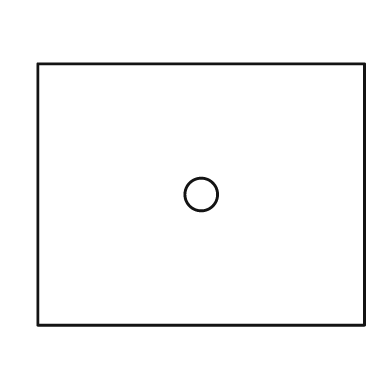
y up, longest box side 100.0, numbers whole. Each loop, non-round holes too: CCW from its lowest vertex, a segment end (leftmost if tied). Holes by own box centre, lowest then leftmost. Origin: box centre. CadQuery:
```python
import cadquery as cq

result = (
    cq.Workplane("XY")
    .moveTo(-50.0, -40.0)
    .lineTo(50.0, -40.0)
    .lineTo(50.0, 40.0)
    .lineTo(-50.0, 40.0)
    .close()
    .moveTo(0.0, 0.0)
    .circle(5.0)
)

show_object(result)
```